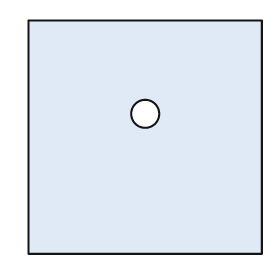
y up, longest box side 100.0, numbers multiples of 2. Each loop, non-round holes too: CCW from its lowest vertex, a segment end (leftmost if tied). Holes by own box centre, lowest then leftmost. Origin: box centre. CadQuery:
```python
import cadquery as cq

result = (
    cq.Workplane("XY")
    .moveTo(-50.0, -50.0)
    .lineTo(50.0, -50.0)
    .lineTo(50.0, 50.0)
    .lineTo(-50.0, 50.0)
    .close()
    .moveTo(0.0, 10.0)
    .circle(6.0)
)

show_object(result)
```